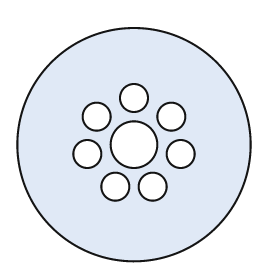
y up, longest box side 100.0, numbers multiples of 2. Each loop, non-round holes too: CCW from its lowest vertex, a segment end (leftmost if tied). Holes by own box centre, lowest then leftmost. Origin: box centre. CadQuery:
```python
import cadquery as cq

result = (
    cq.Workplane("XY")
    .moveTo(0.0, 0.0)
    .circle(50.0)
    .moveTo(-8.0, -18.0)
    .circle(6.0)
    .moveTo(8.0, -18.0)
    .circle(6.0)
    .moveTo(-20.0, -4.0)
    .circle(6.0)
    .moveTo(20.0, -4.0)
    .circle(6.0)
    .moveTo(0.0, 0.0)
    .circle(10.0)
    .moveTo(-16.0, 12.0)
    .circle(6.0)
    .moveTo(16.0, 12.0)
    .circle(6.0)
    .moveTo(0.0, 20.0)
    .circle(6.0)
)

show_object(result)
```